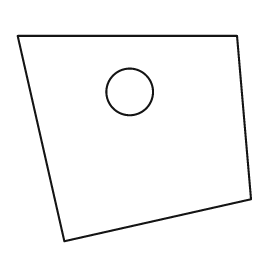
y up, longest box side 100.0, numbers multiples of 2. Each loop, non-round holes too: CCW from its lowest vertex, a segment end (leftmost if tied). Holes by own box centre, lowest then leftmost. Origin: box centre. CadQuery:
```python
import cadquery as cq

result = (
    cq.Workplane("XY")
    .moveTo(-30.0, -44.0)
    .lineTo(50.0, -26.0)
    .lineTo(44.0, 44.0)
    .lineTo(-50.0, 44.0)
    .close()
    .moveTo(-2.0, 20.0)
    .circle(10.0)
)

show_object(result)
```